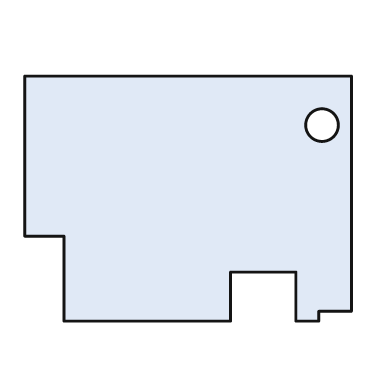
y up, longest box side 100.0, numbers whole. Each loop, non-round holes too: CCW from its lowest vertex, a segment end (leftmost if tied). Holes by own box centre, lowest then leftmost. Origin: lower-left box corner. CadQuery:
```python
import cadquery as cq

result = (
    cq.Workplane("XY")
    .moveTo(12.0, 0.0)
    .lineTo(63.0, 0.0)
    .lineTo(63.0, 15.0)
    .lineTo(83.0, 15.0)
    .lineTo(83.0, 0.0)
    .lineTo(90.0, 0.0)
    .lineTo(90.0, 3.0)
    .lineTo(100.0, 3.0)
    .lineTo(100.0, 75.0)
    .lineTo(0.0, 75.0)
    .lineTo(0.0, 26.0)
    .lineTo(12.0, 26.0)
    .close()
    .moveTo(91.0, 60.0)
    .circle(5.0)
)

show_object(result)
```